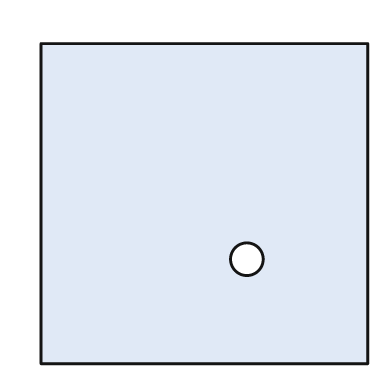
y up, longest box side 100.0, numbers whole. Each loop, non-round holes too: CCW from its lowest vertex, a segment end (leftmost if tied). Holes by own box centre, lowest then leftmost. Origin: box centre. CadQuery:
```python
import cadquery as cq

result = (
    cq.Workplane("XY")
    .moveTo(-50.0, -49.0)
    .lineTo(50.0, -49.0)
    .lineTo(50.0, 49.0)
    .lineTo(-50.0, 49.0)
    .close()
    .moveTo(13.0, -17.0)
    .circle(5.0)
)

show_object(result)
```